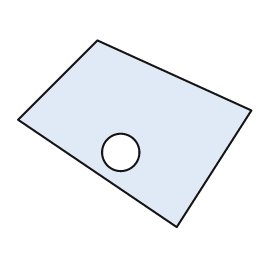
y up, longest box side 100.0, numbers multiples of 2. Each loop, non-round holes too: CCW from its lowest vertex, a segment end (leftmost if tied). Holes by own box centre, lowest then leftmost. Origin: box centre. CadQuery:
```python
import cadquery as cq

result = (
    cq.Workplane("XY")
    .moveTo(18.0, -40.0)
    .lineTo(50.0, 10.0)
    .lineTo(-16.0, 40.0)
    .lineTo(-50.0, 6.0)
    .close()
    .moveTo(-6.0, -8.0)
    .circle(8.0)
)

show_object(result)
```